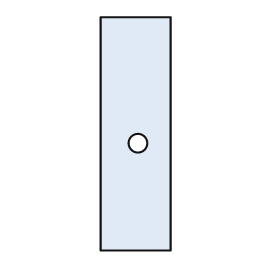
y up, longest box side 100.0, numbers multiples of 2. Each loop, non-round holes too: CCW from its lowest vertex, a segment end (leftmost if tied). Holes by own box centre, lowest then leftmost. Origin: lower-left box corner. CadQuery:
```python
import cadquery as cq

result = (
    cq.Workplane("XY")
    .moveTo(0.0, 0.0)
    .lineTo(30.0, 0.0)
    .lineTo(30.0, 100.0)
    .lineTo(0.0, 100.0)
    .close()
    .moveTo(16.0, 46.0)
    .circle(4.0)
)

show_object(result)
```